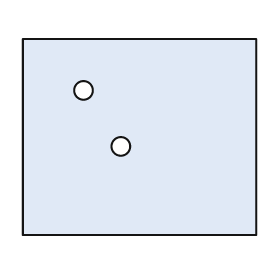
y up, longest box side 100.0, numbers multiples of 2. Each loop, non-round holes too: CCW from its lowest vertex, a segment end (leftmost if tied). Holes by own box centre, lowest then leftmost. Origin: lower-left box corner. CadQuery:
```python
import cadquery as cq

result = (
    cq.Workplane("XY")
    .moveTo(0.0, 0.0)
    .lineTo(100.0, 0.0)
    .lineTo(100.0, 84.0)
    .lineTo(0.0, 84.0)
    .close()
    .moveTo(42.0, 38.0)
    .circle(4.0)
    .moveTo(26.0, 62.0)
    .circle(4.0)
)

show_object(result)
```